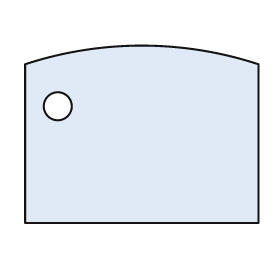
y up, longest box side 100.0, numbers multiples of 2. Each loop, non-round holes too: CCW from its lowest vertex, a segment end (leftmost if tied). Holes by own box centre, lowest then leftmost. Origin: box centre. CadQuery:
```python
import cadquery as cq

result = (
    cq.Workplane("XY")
    .moveTo(-50.0, -38.0)
    .lineTo(50.0, -38.0)
    .lineTo(50.0, 30.0)
    .threePointArc((0.0, 38.0), (-50.0, 30.0))
    .close()
    .moveTo(-36.0, 12.0)
    .circle(6.0)
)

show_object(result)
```